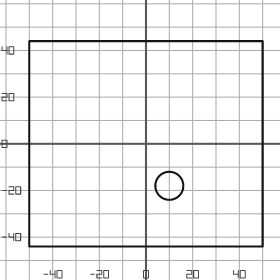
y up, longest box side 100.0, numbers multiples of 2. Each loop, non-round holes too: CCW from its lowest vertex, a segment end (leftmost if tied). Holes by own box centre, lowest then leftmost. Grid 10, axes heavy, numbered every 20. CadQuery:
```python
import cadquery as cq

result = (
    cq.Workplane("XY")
    .moveTo(-50.0, -44.0)
    .lineTo(50.0, -44.0)
    .lineTo(50.0, 44.0)
    .lineTo(-50.0, 44.0)
    .close()
    .moveTo(10.0, -18.0)
    .circle(6.0)
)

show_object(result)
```